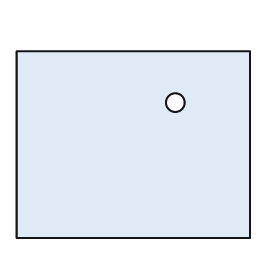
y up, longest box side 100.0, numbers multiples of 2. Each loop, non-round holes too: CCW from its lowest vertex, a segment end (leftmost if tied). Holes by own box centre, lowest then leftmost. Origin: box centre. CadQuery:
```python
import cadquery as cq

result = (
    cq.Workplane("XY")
    .moveTo(-50.0, -40.0)
    .lineTo(50.0, -40.0)
    .lineTo(50.0, 40.0)
    .lineTo(-50.0, 40.0)
    .close()
    .moveTo(18.0, 18.0)
    .circle(4.0)
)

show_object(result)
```